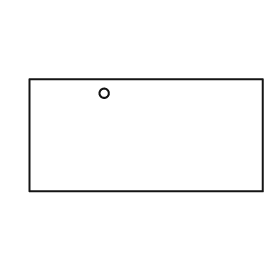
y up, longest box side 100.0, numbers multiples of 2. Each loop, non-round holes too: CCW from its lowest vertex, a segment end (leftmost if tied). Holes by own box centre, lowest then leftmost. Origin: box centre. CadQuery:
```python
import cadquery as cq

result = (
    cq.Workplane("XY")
    .moveTo(-50.0, -24.0)
    .lineTo(50.0, -24.0)
    .lineTo(50.0, 24.0)
    .lineTo(-50.0, 24.0)
    .close()
    .moveTo(-18.0, 18.0)
    .circle(2.0)
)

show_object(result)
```